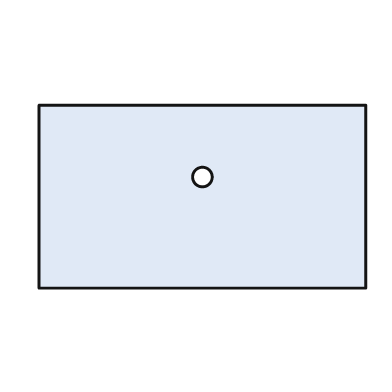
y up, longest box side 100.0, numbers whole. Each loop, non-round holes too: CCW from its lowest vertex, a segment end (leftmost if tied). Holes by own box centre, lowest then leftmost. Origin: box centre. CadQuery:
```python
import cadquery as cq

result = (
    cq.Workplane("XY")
    .moveTo(-50.0, -28.0)
    .lineTo(50.0, -28.0)
    .lineTo(50.0, 28.0)
    .lineTo(-50.0, 28.0)
    .close()
    .moveTo(0.0, 6.0)
    .circle(3.0)
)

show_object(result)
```